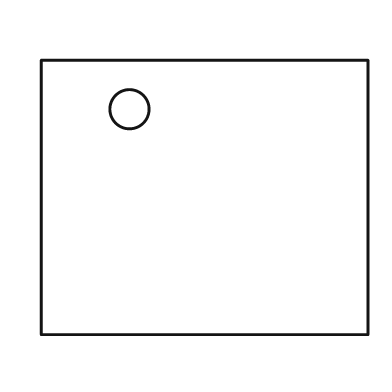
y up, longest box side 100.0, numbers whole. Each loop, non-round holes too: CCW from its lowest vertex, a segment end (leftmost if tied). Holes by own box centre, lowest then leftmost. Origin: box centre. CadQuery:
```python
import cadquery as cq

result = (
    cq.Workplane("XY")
    .moveTo(-50.0, -42.0)
    .lineTo(50.0, -42.0)
    .lineTo(50.0, 42.0)
    .lineTo(-50.0, 42.0)
    .close()
    .moveTo(-23.0, 27.0)
    .circle(6.0)
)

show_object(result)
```